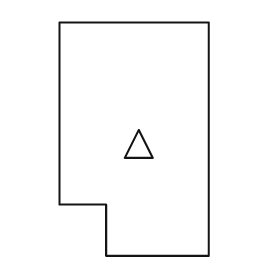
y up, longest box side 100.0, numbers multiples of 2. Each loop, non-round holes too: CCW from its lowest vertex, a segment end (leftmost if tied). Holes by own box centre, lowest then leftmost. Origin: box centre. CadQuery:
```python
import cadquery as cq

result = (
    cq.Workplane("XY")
    .moveTo(-12.0, -50.0)
    .lineTo(32.0, -50.0)
    .lineTo(32.0, 50.0)
    .lineTo(-32.0, 50.0)
    .lineTo(-32.0, -28.0)
    .lineTo(-12.0, -28.0)
    .close()
    .moveTo(-4.0, -8.0)
    .lineTo(8.0, -8.0)
    .lineTo(2.0, 4.0)
    .close()
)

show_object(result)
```